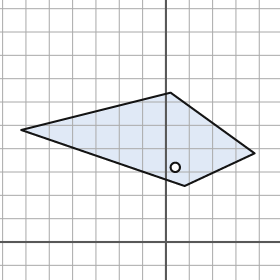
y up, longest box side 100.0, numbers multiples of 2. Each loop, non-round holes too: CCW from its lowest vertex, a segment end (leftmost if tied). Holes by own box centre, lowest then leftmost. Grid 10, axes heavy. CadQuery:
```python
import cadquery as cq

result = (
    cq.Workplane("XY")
    .moveTo(8.0, 24.0)
    .lineTo(38.0, 38.0)
    .lineTo(2.0, 64.0)
    .lineTo(-62.0, 48.0)
    .close()
    .moveTo(4.0, 32.0)
    .circle(2.0)
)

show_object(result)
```